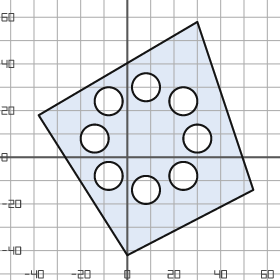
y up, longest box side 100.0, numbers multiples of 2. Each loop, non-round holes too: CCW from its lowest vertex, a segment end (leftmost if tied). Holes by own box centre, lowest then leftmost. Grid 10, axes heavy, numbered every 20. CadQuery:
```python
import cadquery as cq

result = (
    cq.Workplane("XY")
    .moveTo(0.0, -42.0)
    .lineTo(54.0, -14.0)
    .lineTo(30.0, 58.0)
    .lineTo(-38.0, 18.0)
    .close()
    .moveTo(8.0, -14.0)
    .circle(6.0)
    .moveTo(-8.0, -8.0)
    .circle(6.0)
    .moveTo(24.0, -8.0)
    .circle(6.0)
    .moveTo(-14.0, 8.0)
    .circle(6.0)
    .moveTo(30.0, 8.0)
    .circle(6.0)
    .moveTo(-8.0, 24.0)
    .circle(6.0)
    .moveTo(24.0, 24.0)
    .circle(6.0)
    .moveTo(8.0, 30.0)
    .circle(6.0)
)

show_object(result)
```